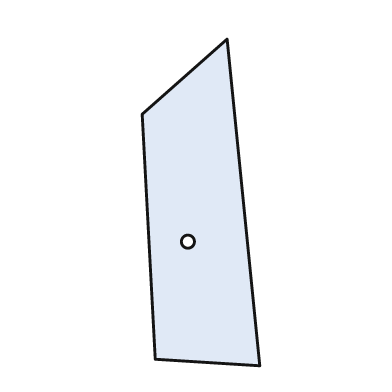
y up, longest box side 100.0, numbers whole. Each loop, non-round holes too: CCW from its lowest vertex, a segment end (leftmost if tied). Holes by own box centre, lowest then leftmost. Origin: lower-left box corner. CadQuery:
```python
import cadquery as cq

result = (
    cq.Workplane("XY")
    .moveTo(36.0, 0.0)
    .lineTo(26.0, 100.0)
    .lineTo(0.0, 77.0)
    .lineTo(4.0, 2.0)
    .close()
    .moveTo(14.0, 38.0)
    .circle(2.0)
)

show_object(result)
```